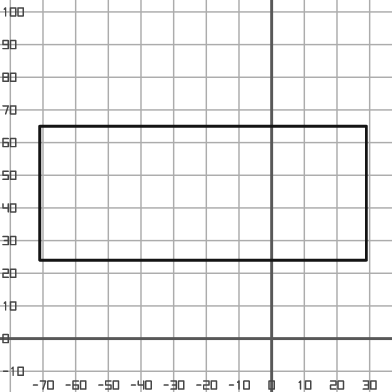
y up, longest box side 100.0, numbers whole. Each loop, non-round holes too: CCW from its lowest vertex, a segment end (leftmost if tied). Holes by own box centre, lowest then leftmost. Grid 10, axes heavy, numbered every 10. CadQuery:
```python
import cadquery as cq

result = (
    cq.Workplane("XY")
    .moveTo(-71.0, 24.0)
    .lineTo(29.0, 24.0)
    .lineTo(29.0, 65.0)
    .lineTo(-71.0, 65.0)
    .close()
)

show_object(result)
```